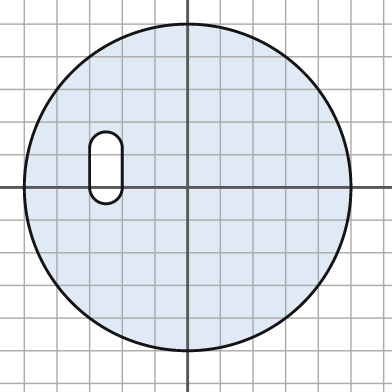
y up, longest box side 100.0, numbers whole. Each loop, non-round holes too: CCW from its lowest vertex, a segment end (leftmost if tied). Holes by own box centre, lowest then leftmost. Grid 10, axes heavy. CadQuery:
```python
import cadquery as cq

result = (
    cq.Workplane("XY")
    .moveTo(0.0, 0.0)
    .circle(50.0)
    .moveTo(-30.0, 0.0)
    .threePointArc((-25.0, -5.0), (-20.0, 0.0))
    .lineTo(-20.0, 12.0)
    .threePointArc((-25.0, 17.0), (-30.0, 12.0))
    .close()
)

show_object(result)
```